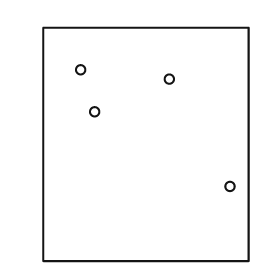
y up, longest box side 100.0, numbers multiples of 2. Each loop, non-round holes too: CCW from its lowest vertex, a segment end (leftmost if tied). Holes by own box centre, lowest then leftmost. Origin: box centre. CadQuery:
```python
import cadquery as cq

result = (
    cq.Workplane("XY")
    .moveTo(-44.0, -50.0)
    .lineTo(44.0, -50.0)
    .lineTo(44.0, 50.0)
    .lineTo(-44.0, 50.0)
    .close()
    .moveTo(36.0, -18.0)
    .circle(2.0)
    .moveTo(-22.0, 14.0)
    .circle(2.0)
    .moveTo(10.0, 28.0)
    .circle(2.0)
    .moveTo(-28.0, 32.0)
    .circle(2.0)
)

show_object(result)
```